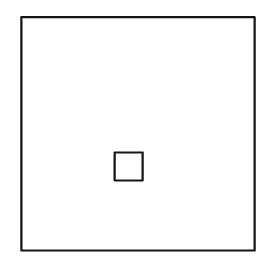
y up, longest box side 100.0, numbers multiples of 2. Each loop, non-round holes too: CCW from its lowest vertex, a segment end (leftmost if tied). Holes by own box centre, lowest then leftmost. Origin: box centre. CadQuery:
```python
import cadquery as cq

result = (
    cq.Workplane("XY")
    .moveTo(-50.0, -50.0)
    .lineTo(50.0, -50.0)
    .lineTo(50.0, 50.0)
    .lineTo(-50.0, 50.0)
    .close()
    .moveTo(-10.0, -20.0)
    .lineTo(2.0, -20.0)
    .lineTo(2.0, -8.0)
    .lineTo(-10.0, -8.0)
    .close()
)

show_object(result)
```